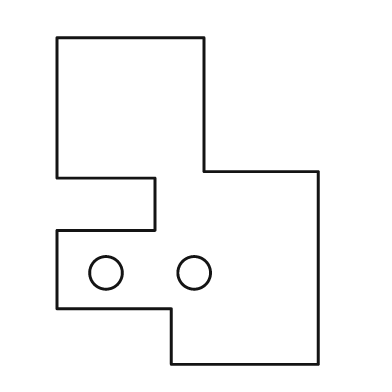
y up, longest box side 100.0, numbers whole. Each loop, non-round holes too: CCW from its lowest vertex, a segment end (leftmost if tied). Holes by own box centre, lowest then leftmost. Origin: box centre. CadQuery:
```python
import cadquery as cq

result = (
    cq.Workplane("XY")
    .moveTo(-5.0, -50.0)
    .lineTo(40.0, -50.0)
    .lineTo(40.0, 9.0)
    .lineTo(5.0, 9.0)
    .lineTo(5.0, 50.0)
    .lineTo(-40.0, 50.0)
    .lineTo(-40.0, 7.0)
    .lineTo(-10.0, 7.0)
    .lineTo(-10.0, -9.0)
    .lineTo(-40.0, -9.0)
    .lineTo(-40.0, -33.0)
    .lineTo(-5.0, -33.0)
    .close()
    .moveTo(-25.0, -22.0)
    .circle(5.0)
    .moveTo(2.0, -22.0)
    .circle(5.0)
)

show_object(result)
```